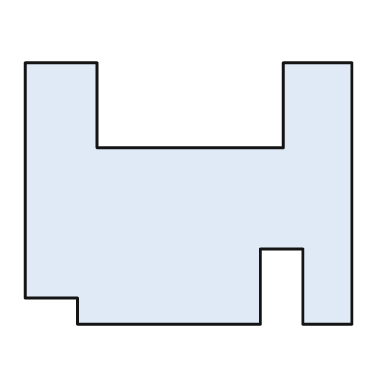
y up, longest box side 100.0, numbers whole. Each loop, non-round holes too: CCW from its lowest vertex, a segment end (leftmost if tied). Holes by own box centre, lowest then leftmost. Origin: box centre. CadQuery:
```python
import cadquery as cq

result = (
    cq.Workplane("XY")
    .moveTo(-34.0, -40.0)
    .lineTo(22.0, -40.0)
    .lineTo(22.0, -17.0)
    .lineTo(35.0, -17.0)
    .lineTo(35.0, -40.0)
    .lineTo(50.0, -40.0)
    .lineTo(50.0, 40.0)
    .lineTo(29.0, 40.0)
    .lineTo(29.0, 14.0)
    .lineTo(-28.0, 14.0)
    .lineTo(-28.0, 40.0)
    .lineTo(-50.0, 40.0)
    .lineTo(-50.0, -32.0)
    .lineTo(-34.0, -32.0)
    .close()
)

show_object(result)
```